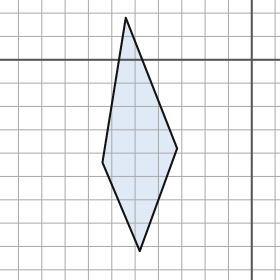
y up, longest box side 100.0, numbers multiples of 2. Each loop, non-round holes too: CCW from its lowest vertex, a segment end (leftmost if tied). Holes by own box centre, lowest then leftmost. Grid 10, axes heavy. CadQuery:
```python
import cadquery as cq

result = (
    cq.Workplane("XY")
    .moveTo(-48.0, -82.0)
    .lineTo(-32.0, -38.0)
    .lineTo(-54.0, 18.0)
    .lineTo(-64.0, -44.0)
    .close()
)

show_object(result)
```